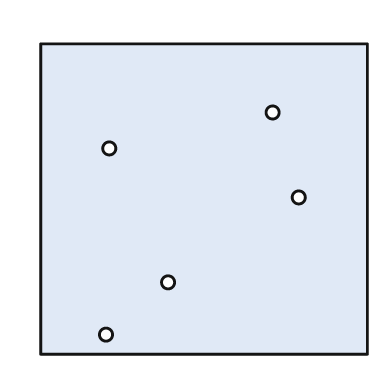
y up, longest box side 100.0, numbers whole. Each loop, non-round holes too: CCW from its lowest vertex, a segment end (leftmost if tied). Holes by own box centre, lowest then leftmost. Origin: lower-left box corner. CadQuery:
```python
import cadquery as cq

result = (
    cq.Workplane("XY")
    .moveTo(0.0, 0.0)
    .lineTo(100.0, 0.0)
    .lineTo(100.0, 95.0)
    .lineTo(0.0, 95.0)
    .close()
    .moveTo(20.0, 6.0)
    .circle(2.0)
    .moveTo(39.0, 22.0)
    .circle(2.0)
    .moveTo(79.0, 48.0)
    .circle(2.0)
    .moveTo(21.0, 63.0)
    .circle(2.0)
    .moveTo(71.0, 74.0)
    .circle(2.0)
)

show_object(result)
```